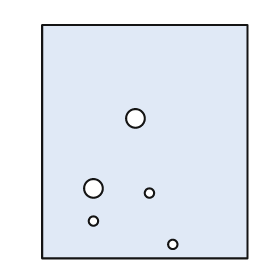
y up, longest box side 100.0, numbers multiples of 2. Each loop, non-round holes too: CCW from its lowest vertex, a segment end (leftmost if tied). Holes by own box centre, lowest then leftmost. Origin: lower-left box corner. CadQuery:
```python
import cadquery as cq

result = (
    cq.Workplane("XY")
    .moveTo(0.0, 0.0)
    .lineTo(88.0, 0.0)
    .lineTo(88.0, 100.0)
    .lineTo(0.0, 100.0)
    .close()
    .moveTo(56.0, 6.0)
    .circle(2.0)
    .moveTo(22.0, 16.0)
    .circle(2.0)
    .moveTo(46.0, 28.0)
    .circle(2.0)
    .moveTo(22.0, 30.0)
    .circle(4.0)
    .moveTo(40.0, 60.0)
    .circle(4.0)
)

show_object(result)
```